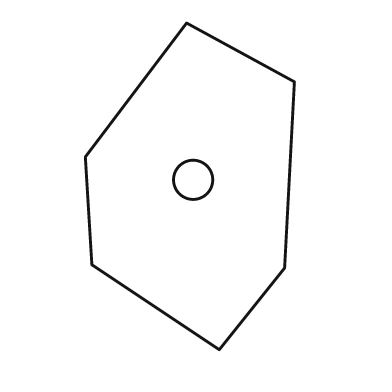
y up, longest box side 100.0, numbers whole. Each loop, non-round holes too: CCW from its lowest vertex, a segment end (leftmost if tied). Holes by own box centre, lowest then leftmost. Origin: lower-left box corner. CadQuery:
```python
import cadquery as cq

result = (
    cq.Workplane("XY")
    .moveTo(41.0, 0.0)
    .lineTo(61.0, 25.0)
    .lineTo(64.0, 82.0)
    .lineTo(31.0, 100.0)
    .lineTo(0.0, 59.0)
    .lineTo(2.0, 26.0)
    .close()
    .moveTo(33.0, 52.0)
    .circle(6.0)
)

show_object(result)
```